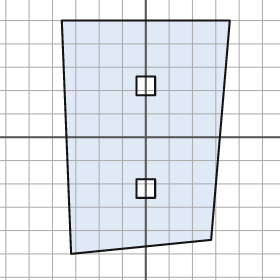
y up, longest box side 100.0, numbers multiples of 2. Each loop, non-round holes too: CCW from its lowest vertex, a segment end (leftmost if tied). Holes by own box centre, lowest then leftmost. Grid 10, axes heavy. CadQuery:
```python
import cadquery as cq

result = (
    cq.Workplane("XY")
    .moveTo(-32.0, -50.0)
    .lineTo(28.0, -44.0)
    .lineTo(36.0, 50.0)
    .lineTo(-36.0, 50.0)
    .close()
    .moveTo(-4.0, -26.0)
    .lineTo(4.0, -26.0)
    .lineTo(4.0, -18.0)
    .lineTo(-4.0, -18.0)
    .close()
    .moveTo(-4.0, 18.0)
    .lineTo(4.0, 18.0)
    .lineTo(4.0, 26.0)
    .lineTo(-4.0, 26.0)
    .close()
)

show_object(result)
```